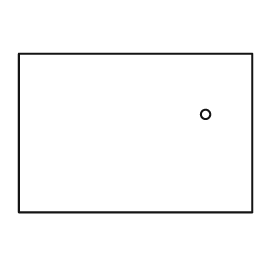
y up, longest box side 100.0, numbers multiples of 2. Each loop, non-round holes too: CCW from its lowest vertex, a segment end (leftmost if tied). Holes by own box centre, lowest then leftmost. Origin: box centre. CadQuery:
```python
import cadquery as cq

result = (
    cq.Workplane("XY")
    .moveTo(-50.0, -34.0)
    .lineTo(50.0, -34.0)
    .lineTo(50.0, 34.0)
    .lineTo(-50.0, 34.0)
    .close()
    .moveTo(30.0, 8.0)
    .circle(2.0)
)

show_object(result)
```